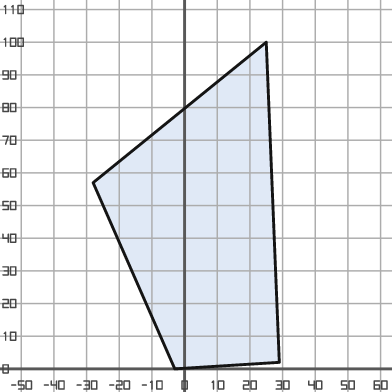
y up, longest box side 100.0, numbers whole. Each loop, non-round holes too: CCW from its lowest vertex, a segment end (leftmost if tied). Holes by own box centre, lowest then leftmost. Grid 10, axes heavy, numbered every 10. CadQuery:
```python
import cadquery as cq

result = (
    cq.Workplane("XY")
    .moveTo(-3.0, 0.0)
    .lineTo(29.0, 2.0)
    .lineTo(25.0, 100.0)
    .lineTo(-28.0, 57.0)
    .close()
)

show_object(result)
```